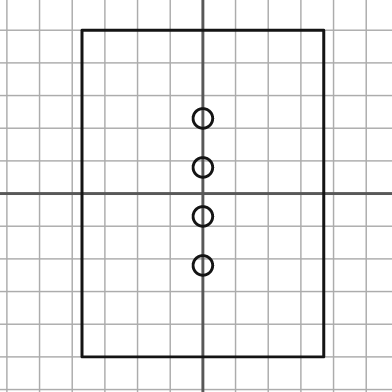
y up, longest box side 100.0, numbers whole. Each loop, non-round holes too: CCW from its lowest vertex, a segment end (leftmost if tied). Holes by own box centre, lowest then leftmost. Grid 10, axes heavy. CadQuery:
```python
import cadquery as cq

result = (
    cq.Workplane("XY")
    .moveTo(-37.0, -50.0)
    .lineTo(37.0, -50.0)
    .lineTo(37.0, 50.0)
    .lineTo(-37.0, 50.0)
    .close()
    .moveTo(0.0, -22.0)
    .circle(3.0)
    .moveTo(0.0, -7.0)
    .circle(3.0)
    .moveTo(0.0, 8.0)
    .circle(3.0)
    .moveTo(0.0, 23.0)
    .circle(3.0)
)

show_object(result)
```